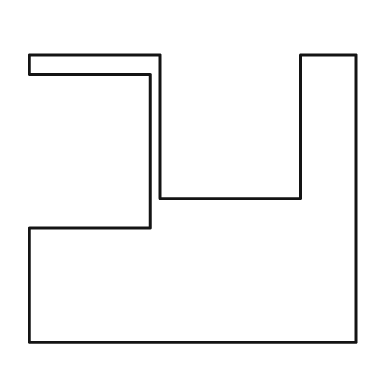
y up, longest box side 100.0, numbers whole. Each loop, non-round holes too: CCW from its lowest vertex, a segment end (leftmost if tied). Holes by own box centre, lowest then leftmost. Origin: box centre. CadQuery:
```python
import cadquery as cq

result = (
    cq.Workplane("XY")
    .moveTo(-50.0, -44.0)
    .lineTo(50.0, -44.0)
    .lineTo(50.0, 44.0)
    .lineTo(33.0, 44.0)
    .lineTo(33.0, 0.0)
    .lineTo(-10.0, 0.0)
    .lineTo(-10.0, 44.0)
    .lineTo(-50.0, 44.0)
    .lineTo(-50.0, 38.0)
    .lineTo(-13.0, 38.0)
    .lineTo(-13.0, -9.0)
    .lineTo(-50.0, -9.0)
    .close()
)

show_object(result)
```